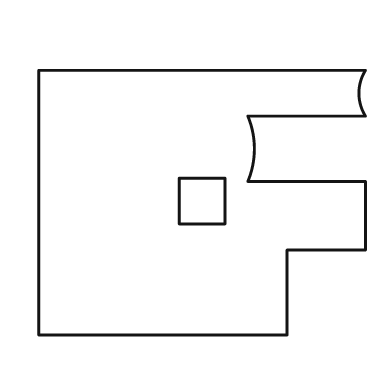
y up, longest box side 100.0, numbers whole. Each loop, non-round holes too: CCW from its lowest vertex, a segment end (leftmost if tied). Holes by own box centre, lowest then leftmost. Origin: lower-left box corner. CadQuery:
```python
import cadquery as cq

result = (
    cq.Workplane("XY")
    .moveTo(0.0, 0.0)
    .lineTo(76.0, 0.0)
    .lineTo(76.0, 26.0)
    .lineTo(100.0, 26.0)
    .lineTo(100.0, 47.0)
    .lineTo(64.0, 47.0)
    .threePointArc((66.0, 57.0), (64.0, 67.0))
    .lineTo(100.0, 67.0)
    .threePointArc((98.0, 74.0), (100.0, 81.0))
    .lineTo(0.0, 81.0)
    .close()
    .moveTo(43.0, 34.0)
    .lineTo(57.0, 34.0)
    .lineTo(57.0, 48.0)
    .lineTo(43.0, 48.0)
    .close()
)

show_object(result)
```